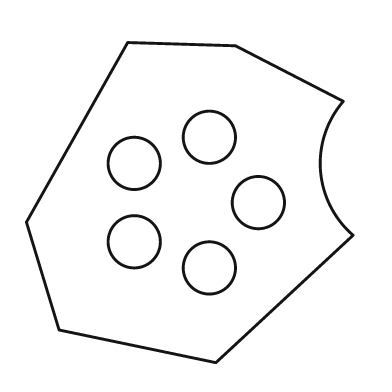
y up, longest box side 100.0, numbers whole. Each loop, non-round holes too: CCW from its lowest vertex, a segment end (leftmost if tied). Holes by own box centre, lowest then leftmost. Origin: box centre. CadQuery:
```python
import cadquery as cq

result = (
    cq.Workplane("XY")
    .moveTo(8.0, -49.0)
    .lineTo(50.0, -10.0)
    .threePointArc((40.0, 10.0), (47.0, 31.0))
    .lineTo(14.0, 48.0)
    .lineTo(-19.0, 49.0)
    .lineTo(-50.0, -6.0)
    .lineTo(-40.0, -39.0)
    .close()
    .moveTo(6.0, -20.0)
    .circle(8.0)
    .moveTo(-17.0, -12.0)
    .circle(8.0)
    .moveTo(21.0, 0.0)
    .circle(8.0)
    .moveTo(-17.0, 12.0)
    .circle(8.0)
    .moveTo(6.0, 20.0)
    .circle(8.0)
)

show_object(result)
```